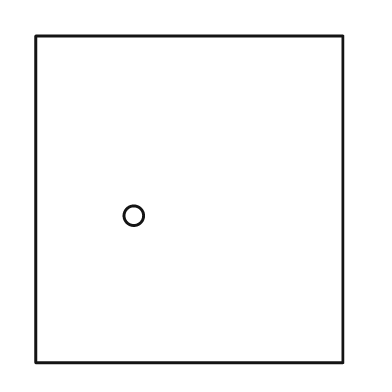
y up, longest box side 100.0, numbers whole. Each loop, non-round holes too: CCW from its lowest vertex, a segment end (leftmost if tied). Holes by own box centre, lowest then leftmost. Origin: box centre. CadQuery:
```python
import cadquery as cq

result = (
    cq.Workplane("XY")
    .moveTo(-47.0, -50.0)
    .lineTo(47.0, -50.0)
    .lineTo(47.0, 50.0)
    .lineTo(-47.0, 50.0)
    .close()
    .moveTo(-17.0, -5.0)
    .circle(3.0)
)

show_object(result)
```